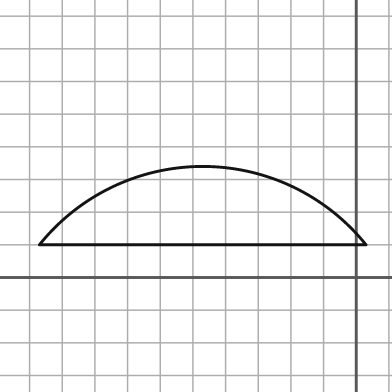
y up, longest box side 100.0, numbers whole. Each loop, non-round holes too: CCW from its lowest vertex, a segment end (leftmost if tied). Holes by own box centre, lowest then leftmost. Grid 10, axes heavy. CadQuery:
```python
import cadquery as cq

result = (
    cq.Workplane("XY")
    .moveTo(-97.0, 10.0)
    .lineTo(3.0, 10.0)
    .threePointArc((-47.0, 34.0), (-97.0, 10.0))
    .close()
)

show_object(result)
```